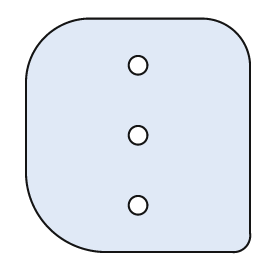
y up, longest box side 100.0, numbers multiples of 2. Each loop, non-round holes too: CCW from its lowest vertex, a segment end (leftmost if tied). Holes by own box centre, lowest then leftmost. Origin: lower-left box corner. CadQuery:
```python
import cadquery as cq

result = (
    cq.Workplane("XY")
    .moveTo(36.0, 0.0)
    .lineTo(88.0, 0.0)
    .threePointArc((94.0, 2.0), (96.0, 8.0))
    .lineTo(96.0, 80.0)
    .threePointArc((90.0, 94.0), (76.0, 100.0))
    .lineTo(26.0, 100.0)
    .threePointArc((8.0, 92.0), (0.0, 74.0))
    .lineTo(0.0, 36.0)
    .threePointArc((10.0, 10.0), (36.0, 0.0))
    .close()
    .moveTo(48.0, 20.0)
    .circle(4.0)
    .moveTo(48.0, 50.0)
    .circle(4.0)
    .moveTo(48.0, 80.0)
    .circle(4.0)
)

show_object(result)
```